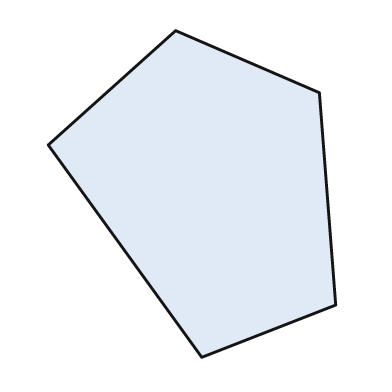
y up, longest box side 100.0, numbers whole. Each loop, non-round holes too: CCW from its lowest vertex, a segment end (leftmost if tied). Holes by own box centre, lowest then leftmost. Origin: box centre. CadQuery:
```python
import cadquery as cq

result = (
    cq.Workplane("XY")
    .moveTo(3.0, -50.0)
    .lineTo(44.0, -34.0)
    .lineTo(39.0, 31.0)
    .lineTo(-5.0, 50.0)
    .lineTo(-44.0, 15.0)
    .close()
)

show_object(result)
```